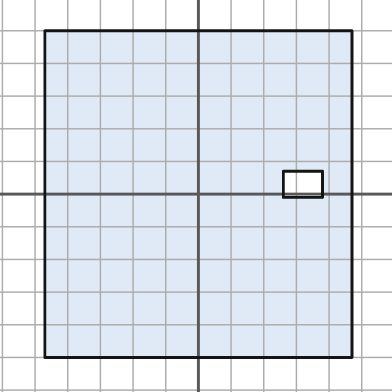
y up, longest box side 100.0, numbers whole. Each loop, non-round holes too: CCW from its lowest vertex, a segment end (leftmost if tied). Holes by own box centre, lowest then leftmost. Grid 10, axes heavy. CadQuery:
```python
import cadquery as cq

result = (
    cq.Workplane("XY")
    .moveTo(-47.0, -50.0)
    .lineTo(47.0, -50.0)
    .lineTo(47.0, 50.0)
    .lineTo(-47.0, 50.0)
    .close()
    .moveTo(26.0, -1.0)
    .lineTo(38.0, -1.0)
    .lineTo(38.0, 7.0)
    .lineTo(26.0, 7.0)
    .close()
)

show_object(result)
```